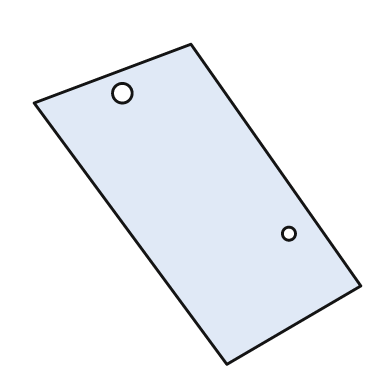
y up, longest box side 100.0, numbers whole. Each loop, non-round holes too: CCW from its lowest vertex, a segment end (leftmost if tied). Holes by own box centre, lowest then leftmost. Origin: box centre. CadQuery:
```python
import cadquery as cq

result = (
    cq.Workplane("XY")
    .moveTo(9.0, -49.0)
    .lineTo(50.0, -25.0)
    .lineTo(-2.0, 49.0)
    .lineTo(-50.0, 31.0)
    .close()
    .moveTo(28.0, -9.0)
    .circle(2.0)
    .moveTo(-23.0, 34.0)
    .circle(3.0)
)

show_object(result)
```